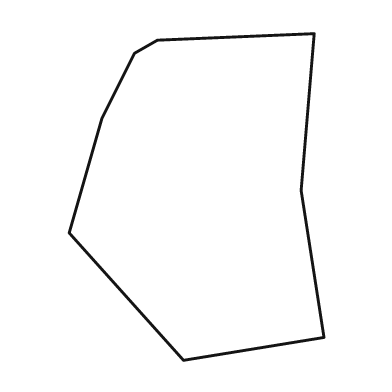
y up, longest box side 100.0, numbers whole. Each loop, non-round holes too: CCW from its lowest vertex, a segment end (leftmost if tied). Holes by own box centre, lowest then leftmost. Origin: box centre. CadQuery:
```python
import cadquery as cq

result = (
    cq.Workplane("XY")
    .moveTo(-4.0, -50.0)
    .lineTo(39.0, -43.0)
    .lineTo(32.0, 2.0)
    .lineTo(36.0, 50.0)
    .lineTo(-12.0, 48.0)
    .lineTo(-19.0, 44.0)
    .lineTo(-29.0, 24.0)
    .lineTo(-39.0, -11.0)
    .close()
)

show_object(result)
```